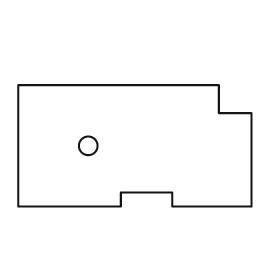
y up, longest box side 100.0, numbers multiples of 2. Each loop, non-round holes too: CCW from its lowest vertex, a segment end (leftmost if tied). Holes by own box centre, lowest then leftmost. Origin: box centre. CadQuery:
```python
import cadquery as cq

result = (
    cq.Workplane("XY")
    .moveTo(-50.0, -26.0)
    .lineTo(-6.0, -26.0)
    .lineTo(-6.0, -20.0)
    .lineTo(16.0, -20.0)
    .lineTo(16.0, -26.0)
    .lineTo(50.0, -26.0)
    .lineTo(50.0, 14.0)
    .lineTo(36.0, 14.0)
    .lineTo(36.0, 26.0)
    .lineTo(-50.0, 26.0)
    .close()
    .moveTo(-20.0, 0.0)
    .circle(4.0)
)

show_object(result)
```